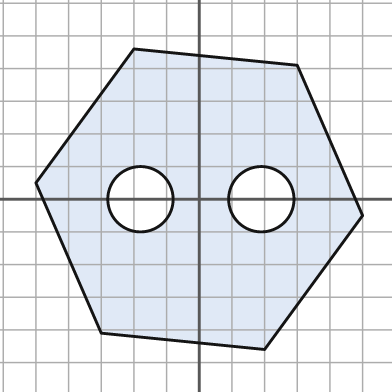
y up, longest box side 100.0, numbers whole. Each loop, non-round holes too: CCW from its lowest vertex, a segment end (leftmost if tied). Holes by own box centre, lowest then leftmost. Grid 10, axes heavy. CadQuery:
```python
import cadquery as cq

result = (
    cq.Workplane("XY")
    .moveTo(20.0, -46.0)
    .lineTo(50.0, -5.0)
    .lineTo(30.0, 41.0)
    .lineTo(-20.0, 46.0)
    .lineTo(-50.0, 5.0)
    .lineTo(-30.0, -41.0)
    .close()
    .moveTo(-18.0, 0.0)
    .circle(10.0)
    .moveTo(19.0, 0.0)
    .circle(10.0)
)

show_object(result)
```